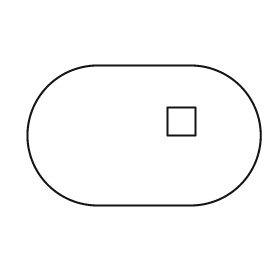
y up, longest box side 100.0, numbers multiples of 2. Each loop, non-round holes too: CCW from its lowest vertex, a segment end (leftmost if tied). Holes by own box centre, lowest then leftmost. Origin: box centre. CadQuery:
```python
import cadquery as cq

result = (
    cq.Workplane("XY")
    .moveTo(-20.0, -30.0)
    .lineTo(20.0, -30.0)
    .threePointArc((50.0, 0.0), (20.0, 30.0))
    .lineTo(-20.0, 30.0)
    .threePointArc((-50.0, 0.0), (-20.0, -30.0))
    .close()
    .moveTo(10.0, 0.0)
    .lineTo(22.0, 0.0)
    .lineTo(22.0, 12.0)
    .lineTo(10.0, 12.0)
    .close()
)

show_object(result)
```